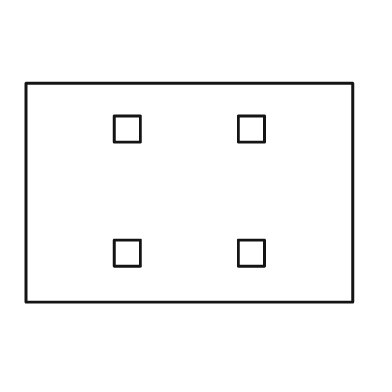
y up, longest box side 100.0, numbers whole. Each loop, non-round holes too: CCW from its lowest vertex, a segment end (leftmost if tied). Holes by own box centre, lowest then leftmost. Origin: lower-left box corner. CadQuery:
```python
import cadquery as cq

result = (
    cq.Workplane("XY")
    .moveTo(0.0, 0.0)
    .lineTo(100.0, 0.0)
    .lineTo(100.0, 67.0)
    .lineTo(0.0, 67.0)
    .close()
    .moveTo(27.0, 11.0)
    .lineTo(35.0, 11.0)
    .lineTo(35.0, 19.0)
    .lineTo(27.0, 19.0)
    .close()
    .moveTo(65.0, 11.0)
    .lineTo(73.0, 11.0)
    .lineTo(73.0, 19.0)
    .lineTo(65.0, 19.0)
    .close()
    .moveTo(27.0, 49.0)
    .lineTo(35.0, 49.0)
    .lineTo(35.0, 57.0)
    .lineTo(27.0, 57.0)
    .close()
    .moveTo(65.0, 49.0)
    .lineTo(73.0, 49.0)
    .lineTo(73.0, 57.0)
    .lineTo(65.0, 57.0)
    .close()
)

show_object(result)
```